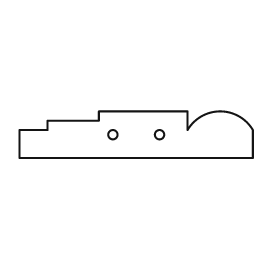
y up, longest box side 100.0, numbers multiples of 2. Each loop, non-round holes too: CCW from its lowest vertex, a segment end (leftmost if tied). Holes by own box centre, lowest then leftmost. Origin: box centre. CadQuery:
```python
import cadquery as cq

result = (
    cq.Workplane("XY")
    .moveTo(-50.0, -10.0)
    .lineTo(50.0, -10.0)
    .lineTo(50.0, 2.0)
    .threePointArc((36.0, 10.0), (22.0, 2.0))
    .lineTo(22.0, 10.0)
    .lineTo(-16.0, 10.0)
    .lineTo(-16.0, 6.0)
    .lineTo(-38.0, 6.0)
    .lineTo(-38.0, 2.0)
    .lineTo(-50.0, 2.0)
    .close()
    .moveTo(-10.0, 0.0)
    .circle(2.0)
    .moveTo(10.0, 0.0)
    .circle(2.0)
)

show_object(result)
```